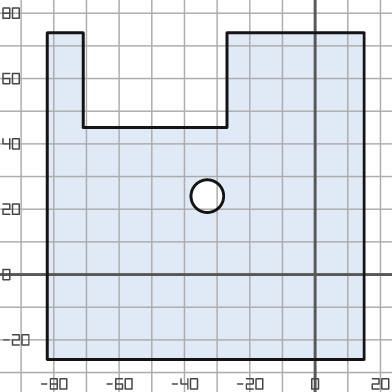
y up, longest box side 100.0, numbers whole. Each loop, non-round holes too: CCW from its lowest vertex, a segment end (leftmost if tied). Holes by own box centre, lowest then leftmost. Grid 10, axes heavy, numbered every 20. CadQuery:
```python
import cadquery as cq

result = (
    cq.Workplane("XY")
    .moveTo(-82.0, -26.0)
    .lineTo(15.0, -26.0)
    .lineTo(15.0, 74.0)
    .lineTo(-27.0, 74.0)
    .lineTo(-27.0, 45.0)
    .lineTo(-71.0, 45.0)
    .lineTo(-71.0, 74.0)
    .lineTo(-82.0, 74.0)
    .close()
    .moveTo(-33.0, 24.0)
    .circle(5.0)
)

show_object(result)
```